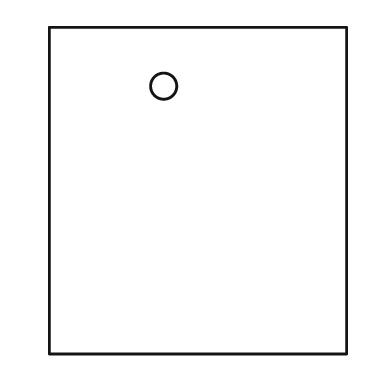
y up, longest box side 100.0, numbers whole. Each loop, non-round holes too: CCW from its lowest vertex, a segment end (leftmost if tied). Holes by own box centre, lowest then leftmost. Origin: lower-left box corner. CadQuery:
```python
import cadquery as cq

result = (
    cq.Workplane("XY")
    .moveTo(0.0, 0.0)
    .lineTo(91.0, 0.0)
    .lineTo(91.0, 100.0)
    .lineTo(0.0, 100.0)
    .close()
    .moveTo(35.0, 82.0)
    .circle(4.0)
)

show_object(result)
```